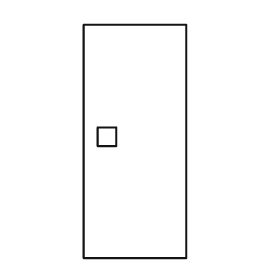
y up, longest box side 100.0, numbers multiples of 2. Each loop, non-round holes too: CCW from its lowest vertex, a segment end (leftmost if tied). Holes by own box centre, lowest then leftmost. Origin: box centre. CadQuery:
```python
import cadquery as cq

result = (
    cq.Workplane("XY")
    .moveTo(-22.0, -50.0)
    .lineTo(22.0, -50.0)
    .lineTo(22.0, 50.0)
    .lineTo(-22.0, 50.0)
    .close()
    .moveTo(-16.0, -2.0)
    .lineTo(-8.0, -2.0)
    .lineTo(-8.0, 6.0)
    .lineTo(-16.0, 6.0)
    .close()
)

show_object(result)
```